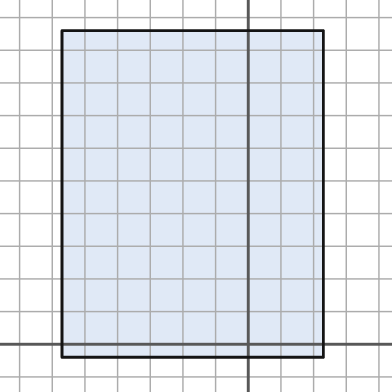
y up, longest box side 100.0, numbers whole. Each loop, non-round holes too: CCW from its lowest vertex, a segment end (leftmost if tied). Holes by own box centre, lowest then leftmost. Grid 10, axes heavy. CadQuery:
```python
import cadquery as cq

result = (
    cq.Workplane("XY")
    .moveTo(-57.0, -4.0)
    .lineTo(23.0, -4.0)
    .lineTo(23.0, 96.0)
    .lineTo(-57.0, 96.0)
    .close()
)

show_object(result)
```